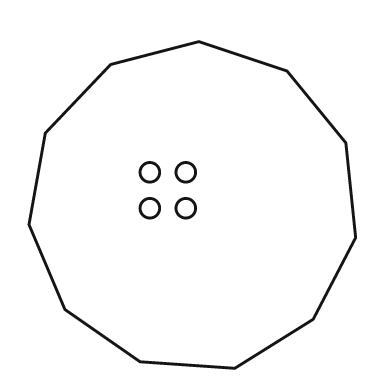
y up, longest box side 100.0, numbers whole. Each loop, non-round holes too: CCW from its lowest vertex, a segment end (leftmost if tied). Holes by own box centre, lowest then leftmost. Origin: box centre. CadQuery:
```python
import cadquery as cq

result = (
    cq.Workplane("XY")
    .moveTo(13.0, -50.0)
    .lineTo(37.0, -35.0)
    .lineTo(50.0, -10.0)
    .lineTo(47.0, 19.0)
    .lineTo(29.0, 41.0)
    .lineTo(2.0, 50.0)
    .lineTo(-25.0, 43.0)
    .lineTo(-45.0, 22.0)
    .lineTo(-50.0, -6.0)
    .lineTo(-39.0, -32.0)
    .lineTo(-16.0, -48.0)
    .close()
    .moveTo(-13.0, -1.0)
    .circle(3.0)
    .moveTo(-2.0, -1.0)
    .circle(3.0)
    .moveTo(-13.0, 10.0)
    .circle(3.0)
    .moveTo(-2.0, 10.0)
    .circle(3.0)
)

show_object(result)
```